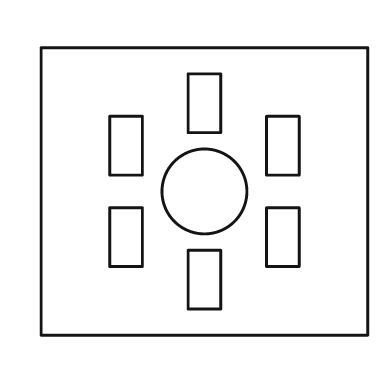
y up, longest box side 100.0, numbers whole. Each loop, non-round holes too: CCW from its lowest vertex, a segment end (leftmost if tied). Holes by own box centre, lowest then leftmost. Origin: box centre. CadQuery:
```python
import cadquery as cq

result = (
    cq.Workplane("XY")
    .moveTo(-50.0, -44.0)
    .lineTo(50.0, -44.0)
    .lineTo(50.0, 44.0)
    .lineTo(-50.0, 44.0)
    .close()
    .moveTo(-5.0, -36.0)
    .lineTo(5.0, -36.0)
    .lineTo(5.0, -18.0)
    .lineTo(-5.0, -18.0)
    .close()
    .moveTo(-29.0, -23.0)
    .lineTo(-19.0, -23.0)
    .lineTo(-19.0, -5.0)
    .lineTo(-29.0, -5.0)
    .close()
    .moveTo(19.0, -23.0)
    .lineTo(29.0, -23.0)
    .lineTo(29.0, -5.0)
    .lineTo(19.0, -5.0)
    .close()
    .moveTo(0.0, 0.0)
    .circle(13.0)
    .moveTo(-29.0, 5.0)
    .lineTo(-19.0, 5.0)
    .lineTo(-19.0, 23.0)
    .lineTo(-29.0, 23.0)
    .close()
    .moveTo(19.0, 5.0)
    .lineTo(29.0, 5.0)
    .lineTo(29.0, 23.0)
    .lineTo(19.0, 23.0)
    .close()
    .moveTo(-5.0, 18.0)
    .lineTo(5.0, 18.0)
    .lineTo(5.0, 36.0)
    .lineTo(-5.0, 36.0)
    .close()
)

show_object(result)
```